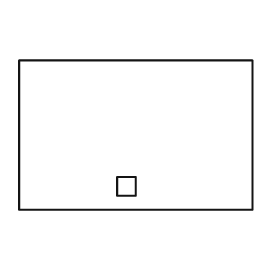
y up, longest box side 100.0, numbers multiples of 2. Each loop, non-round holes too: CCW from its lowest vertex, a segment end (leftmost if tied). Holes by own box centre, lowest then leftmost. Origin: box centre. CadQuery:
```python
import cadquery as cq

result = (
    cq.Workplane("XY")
    .moveTo(-50.0, -32.0)
    .lineTo(50.0, -32.0)
    .lineTo(50.0, 32.0)
    .lineTo(-50.0, 32.0)
    .close()
    .moveTo(-8.0, -26.0)
    .lineTo(0.0, -26.0)
    .lineTo(0.0, -18.0)
    .lineTo(-8.0, -18.0)
    .close()
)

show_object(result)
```